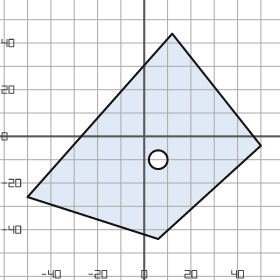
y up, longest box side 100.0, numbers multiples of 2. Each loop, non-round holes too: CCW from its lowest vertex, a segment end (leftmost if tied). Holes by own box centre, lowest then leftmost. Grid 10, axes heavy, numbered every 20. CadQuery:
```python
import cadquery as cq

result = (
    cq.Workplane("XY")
    .moveTo(6.0, -44.0)
    .lineTo(50.0, -4.0)
    .lineTo(12.0, 44.0)
    .lineTo(-50.0, -26.0)
    .close()
    .moveTo(6.0, -10.0)
    .circle(4.0)
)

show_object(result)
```